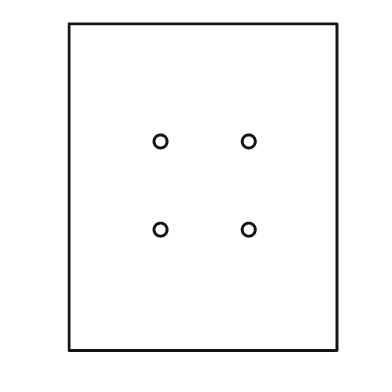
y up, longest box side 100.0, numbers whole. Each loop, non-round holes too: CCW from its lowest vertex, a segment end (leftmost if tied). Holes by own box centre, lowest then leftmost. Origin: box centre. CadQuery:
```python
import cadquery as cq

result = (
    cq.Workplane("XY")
    .moveTo(-41.0, -50.0)
    .lineTo(41.0, -50.0)
    .lineTo(41.0, 50.0)
    .lineTo(-41.0, 50.0)
    .close()
    .moveTo(-13.0, -13.0)
    .circle(2.0)
    .moveTo(14.0, -13.0)
    .circle(2.0)
    .moveTo(-13.0, 14.0)
    .circle(2.0)
    .moveTo(14.0, 14.0)
    .circle(2.0)
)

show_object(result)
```